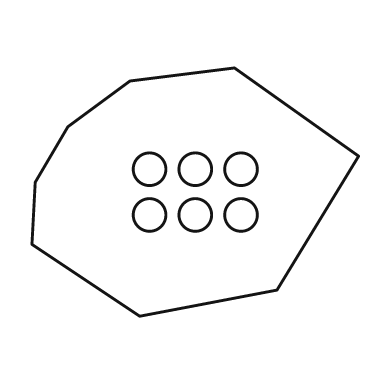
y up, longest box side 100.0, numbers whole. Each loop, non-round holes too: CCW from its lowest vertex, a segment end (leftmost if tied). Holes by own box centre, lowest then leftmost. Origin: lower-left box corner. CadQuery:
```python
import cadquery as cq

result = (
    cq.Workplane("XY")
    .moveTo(33.0, 0.0)
    .lineTo(75.0, 8.0)
    .lineTo(100.0, 49.0)
    .lineTo(62.0, 76.0)
    .lineTo(30.0, 72.0)
    .lineTo(11.0, 58.0)
    .lineTo(1.0, 41.0)
    .lineTo(0.0, 22.0)
    .close()
    .moveTo(36.0, 31.0)
    .circle(5.0)
    .moveTo(50.0, 31.0)
    .circle(5.0)
    .moveTo(64.0, 31.0)
    .circle(5.0)
    .moveTo(36.0, 45.0)
    .circle(5.0)
    .moveTo(50.0, 45.0)
    .circle(5.0)
    .moveTo(64.0, 45.0)
    .circle(5.0)
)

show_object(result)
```